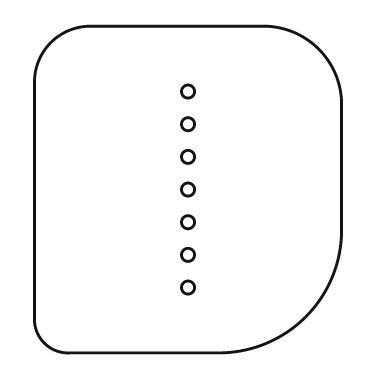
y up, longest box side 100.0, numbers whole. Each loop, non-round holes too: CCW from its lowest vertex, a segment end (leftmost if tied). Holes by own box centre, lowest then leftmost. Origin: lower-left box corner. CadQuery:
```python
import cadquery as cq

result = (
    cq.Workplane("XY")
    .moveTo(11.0, 0.0)
    .lineTo(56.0, 0.0)
    .threePointArc((83.0, 11.0), (94.0, 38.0))
    .lineTo(94.0, 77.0)
    .threePointArc((87.0, 93.0), (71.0, 100.0))
    .lineTo(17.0, 100.0)
    .threePointArc((5.0, 95.0), (0.0, 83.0))
    .lineTo(0.0, 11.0)
    .threePointArc((3.0, 3.0), (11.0, 0.0))
    .close()
    .moveTo(47.0, 20.0)
    .circle(2.0)
    .moveTo(47.0, 30.0)
    .circle(2.0)
    .moveTo(47.0, 40.0)
    .circle(2.0)
    .moveTo(47.0, 50.0)
    .circle(2.0)
    .moveTo(47.0, 60.0)
    .circle(2.0)
    .moveTo(47.0, 70.0)
    .circle(2.0)
    .moveTo(47.0, 80.0)
    .circle(2.0)
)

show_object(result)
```